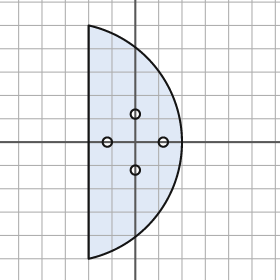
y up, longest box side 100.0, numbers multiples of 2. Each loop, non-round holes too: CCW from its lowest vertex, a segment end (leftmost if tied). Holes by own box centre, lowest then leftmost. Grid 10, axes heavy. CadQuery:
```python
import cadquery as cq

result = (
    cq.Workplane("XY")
    .moveTo(-20.0, -50.0)
    .threePointArc((20.0, 0.0), (-20.0, 50.0))
    .close()
    .moveTo(0.0, -12.0)
    .circle(2.0)
    .moveTo(-12.0, 0.0)
    .circle(2.0)
    .moveTo(12.0, 0.0)
    .circle(2.0)
    .moveTo(0.0, 12.0)
    .circle(2.0)
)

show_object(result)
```